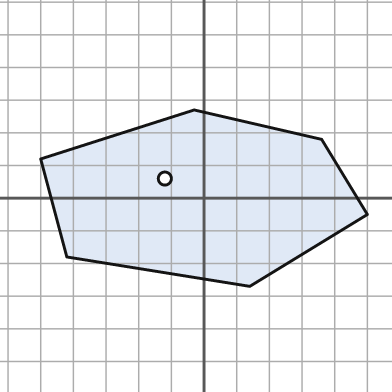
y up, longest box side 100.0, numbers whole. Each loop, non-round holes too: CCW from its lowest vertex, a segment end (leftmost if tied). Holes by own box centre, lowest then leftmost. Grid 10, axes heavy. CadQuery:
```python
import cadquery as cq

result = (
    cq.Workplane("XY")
    .moveTo(14.0, -27.0)
    .lineTo(50.0, -5.0)
    .lineTo(36.0, 18.0)
    .lineTo(-3.0, 27.0)
    .lineTo(-50.0, 12.0)
    .lineTo(-42.0, -18.0)
    .close()
    .moveTo(-12.0, 6.0)
    .circle(2.0)
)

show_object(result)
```